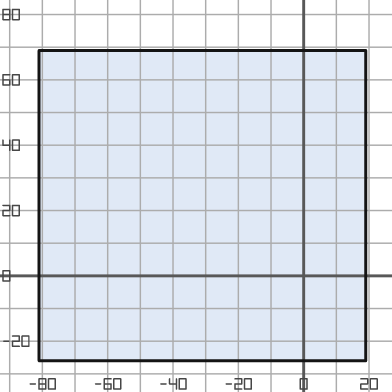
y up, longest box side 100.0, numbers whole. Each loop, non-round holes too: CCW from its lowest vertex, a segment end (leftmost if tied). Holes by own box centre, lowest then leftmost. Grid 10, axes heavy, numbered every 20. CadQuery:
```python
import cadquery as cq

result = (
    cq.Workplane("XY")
    .moveTo(-81.0, -26.0)
    .lineTo(19.0, -26.0)
    .lineTo(19.0, 69.0)
    .lineTo(-81.0, 69.0)
    .close()
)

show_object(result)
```